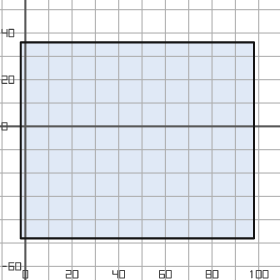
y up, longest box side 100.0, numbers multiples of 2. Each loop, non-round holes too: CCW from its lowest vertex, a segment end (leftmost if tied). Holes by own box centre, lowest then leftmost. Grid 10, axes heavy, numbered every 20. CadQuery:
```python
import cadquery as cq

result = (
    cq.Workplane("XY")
    .moveTo(-2.0, -48.0)
    .lineTo(98.0, -48.0)
    .lineTo(98.0, 36.0)
    .lineTo(-2.0, 36.0)
    .close()
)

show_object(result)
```